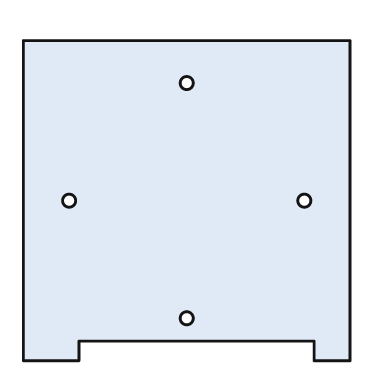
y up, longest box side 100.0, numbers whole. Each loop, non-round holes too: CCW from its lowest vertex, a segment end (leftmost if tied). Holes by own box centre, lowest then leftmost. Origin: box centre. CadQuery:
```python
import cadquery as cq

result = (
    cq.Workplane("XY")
    .moveTo(-50.0, -49.0)
    .lineTo(-33.0, -49.0)
    .lineTo(-33.0, -43.0)
    .lineTo(39.0, -43.0)
    .lineTo(39.0, -49.0)
    .lineTo(50.0, -49.0)
    .lineTo(50.0, 49.0)
    .lineTo(-50.0, 49.0)
    .close()
    .moveTo(0.0, -36.0)
    .circle(2.0)
    .moveTo(-36.0, 0.0)
    .circle(2.0)
    .moveTo(36.0, 0.0)
    .circle(2.0)
    .moveTo(0.0, 36.0)
    .circle(2.0)
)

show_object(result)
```